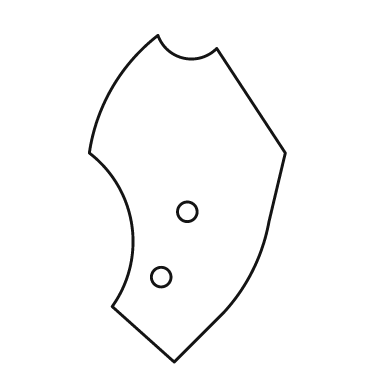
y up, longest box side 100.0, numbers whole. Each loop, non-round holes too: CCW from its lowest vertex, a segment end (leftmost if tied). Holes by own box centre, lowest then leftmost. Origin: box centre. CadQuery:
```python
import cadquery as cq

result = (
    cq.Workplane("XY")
    .moveTo(-4.0, -50.0)
    .lineTo(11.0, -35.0)
    .threePointArc((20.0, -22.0), (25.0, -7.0))
    .lineTo(30.0, 14.0)
    .lineTo(9.0, 46.0)
    .threePointArc((-1.0, 43.0), (-9.0, 50.0))
    .threePointArc((-23.0, 34.0), (-30.0, 14.0))
    .threePointArc((-17.0, -8.0), (-23.0, -33.0))
    .close()
    .moveTo(-8.0, -24.0)
    .circle(3.0)
    .moveTo(0.0, -4.0)
    .circle(3.0)
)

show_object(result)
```